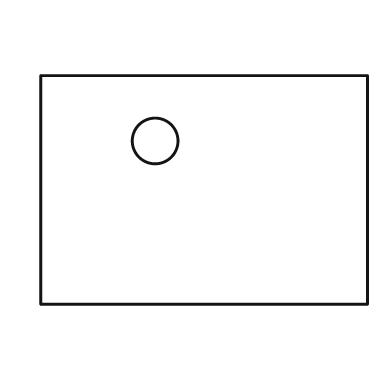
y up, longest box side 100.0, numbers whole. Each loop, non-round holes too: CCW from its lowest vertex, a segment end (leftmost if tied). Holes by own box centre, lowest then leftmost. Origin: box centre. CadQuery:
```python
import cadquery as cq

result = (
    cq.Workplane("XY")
    .moveTo(-50.0, -35.0)
    .lineTo(50.0, -35.0)
    .lineTo(50.0, 35.0)
    .lineTo(-50.0, 35.0)
    .close()
    .moveTo(-15.0, 15.0)
    .circle(7.0)
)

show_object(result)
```